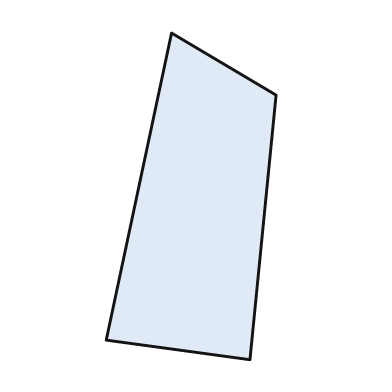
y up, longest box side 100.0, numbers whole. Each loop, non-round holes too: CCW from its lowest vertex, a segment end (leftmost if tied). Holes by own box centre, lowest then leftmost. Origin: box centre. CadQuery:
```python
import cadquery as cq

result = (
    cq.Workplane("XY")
    .moveTo(18.0, -50.0)
    .lineTo(26.0, 31.0)
    .lineTo(-6.0, 50.0)
    .lineTo(-26.0, -44.0)
    .close()
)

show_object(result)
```